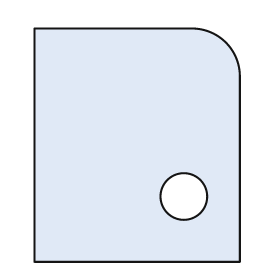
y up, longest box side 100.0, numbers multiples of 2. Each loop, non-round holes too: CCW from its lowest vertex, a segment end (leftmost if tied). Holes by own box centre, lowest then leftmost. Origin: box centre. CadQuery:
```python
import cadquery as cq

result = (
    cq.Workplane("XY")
    .moveTo(-44.0, -50.0)
    .lineTo(44.0, -50.0)
    .lineTo(44.0, 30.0)
    .threePointArc((38.0, 44.0), (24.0, 50.0))
    .lineTo(-44.0, 50.0)
    .close()
    .moveTo(20.0, -22.0)
    .circle(10.0)
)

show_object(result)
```